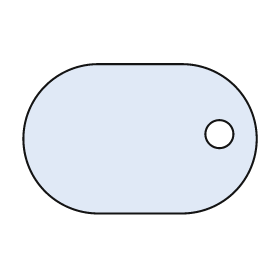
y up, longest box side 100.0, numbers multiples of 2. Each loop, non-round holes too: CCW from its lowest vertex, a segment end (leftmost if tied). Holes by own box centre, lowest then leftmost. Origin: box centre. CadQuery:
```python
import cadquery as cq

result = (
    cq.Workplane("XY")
    .moveTo(-18.0, -32.0)
    .lineTo(18.0, -32.0)
    .threePointArc((50.0, 0.0), (18.0, 32.0))
    .lineTo(-18.0, 32.0)
    .threePointArc((-50.0, 0.0), (-18.0, -32.0))
    .close()
    .moveTo(34.0, 2.0)
    .circle(6.0)
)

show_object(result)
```